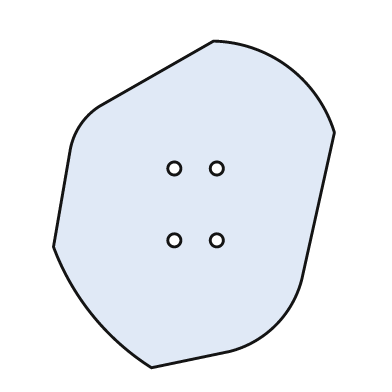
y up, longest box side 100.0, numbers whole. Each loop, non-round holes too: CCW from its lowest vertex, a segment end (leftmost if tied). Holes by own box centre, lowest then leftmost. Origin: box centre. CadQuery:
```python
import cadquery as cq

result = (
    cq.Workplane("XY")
    .moveTo(-13.0, -50.0)
    .lineTo(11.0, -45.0)
    .threePointArc((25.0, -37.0), (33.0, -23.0))
    .lineTo(43.0, 22.0)
    .threePointArc((29.0, 42.0), (6.0, 50.0))
    .lineTo(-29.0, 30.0)
    .threePointArc((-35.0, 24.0), (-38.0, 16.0))
    .lineTo(-43.0, -13.0)
    .threePointArc((-31.0, -34.0), (-13.0, -50.0))
    .close()
    .moveTo(-6.0, -11.0)
    .circle(2.0)
    .moveTo(7.0, -11.0)
    .circle(2.0)
    .moveTo(-6.0, 11.0)
    .circle(2.0)
    .moveTo(7.0, 11.0)
    .circle(2.0)
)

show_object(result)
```